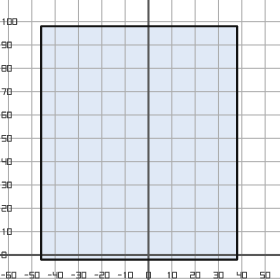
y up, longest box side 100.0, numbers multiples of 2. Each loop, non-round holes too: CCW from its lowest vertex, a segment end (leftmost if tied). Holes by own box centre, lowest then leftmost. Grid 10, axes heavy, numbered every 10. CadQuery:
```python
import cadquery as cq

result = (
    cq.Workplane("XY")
    .moveTo(-46.0, -2.0)
    .lineTo(38.0, -2.0)
    .lineTo(38.0, 98.0)
    .lineTo(-46.0, 98.0)
    .close()
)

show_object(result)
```